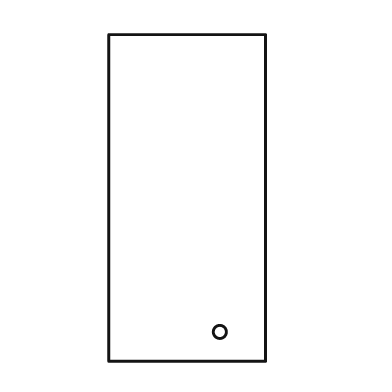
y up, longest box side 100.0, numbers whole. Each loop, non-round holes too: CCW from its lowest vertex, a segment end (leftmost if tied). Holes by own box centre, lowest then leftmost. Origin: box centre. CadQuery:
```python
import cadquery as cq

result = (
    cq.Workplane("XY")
    .moveTo(-24.0, -50.0)
    .lineTo(24.0, -50.0)
    .lineTo(24.0, 50.0)
    .lineTo(-24.0, 50.0)
    .close()
    .moveTo(10.0, -41.0)
    .circle(2.0)
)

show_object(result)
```